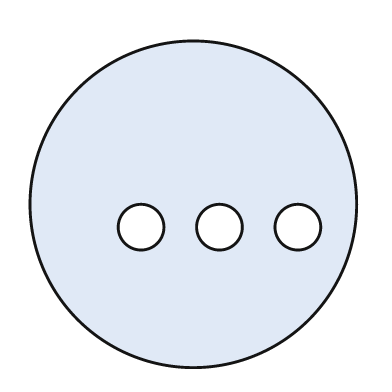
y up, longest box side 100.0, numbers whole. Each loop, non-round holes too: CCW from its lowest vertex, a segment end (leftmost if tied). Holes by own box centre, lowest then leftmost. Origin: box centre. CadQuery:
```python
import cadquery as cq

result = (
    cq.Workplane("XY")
    .moveTo(0.0, 0.0)
    .circle(50.0)
    .moveTo(-16.0, -7.0)
    .circle(7.0)
    .moveTo(8.0, -7.0)
    .circle(7.0)
    .moveTo(32.0, -7.0)
    .circle(7.0)
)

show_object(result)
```